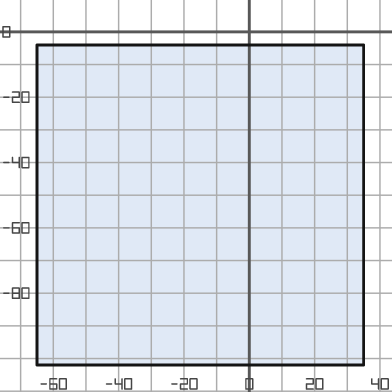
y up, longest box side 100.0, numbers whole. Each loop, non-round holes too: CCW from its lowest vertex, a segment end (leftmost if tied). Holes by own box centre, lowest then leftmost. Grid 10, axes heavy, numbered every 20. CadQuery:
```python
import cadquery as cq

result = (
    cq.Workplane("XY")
    .moveTo(-65.0, -102.0)
    .lineTo(35.0, -102.0)
    .lineTo(35.0, -4.0)
    .lineTo(-65.0, -4.0)
    .close()
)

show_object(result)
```